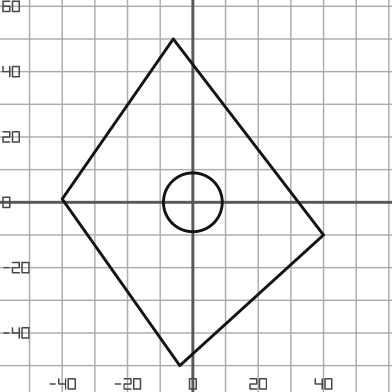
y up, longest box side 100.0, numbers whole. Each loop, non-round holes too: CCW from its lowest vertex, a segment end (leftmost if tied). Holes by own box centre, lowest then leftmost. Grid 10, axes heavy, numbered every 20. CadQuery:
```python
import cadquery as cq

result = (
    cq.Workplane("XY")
    .moveTo(-4.0, -50.0)
    .lineTo(40.0, -10.0)
    .lineTo(-6.0, 50.0)
    .lineTo(-40.0, 1.0)
    .close()
    .moveTo(0.0, 0.0)
    .circle(9.0)
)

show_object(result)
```